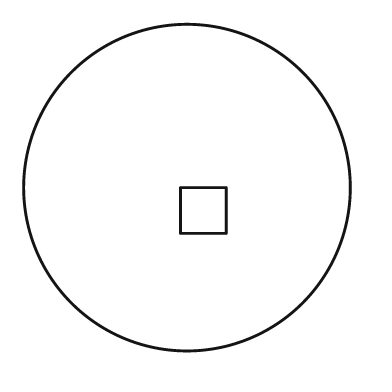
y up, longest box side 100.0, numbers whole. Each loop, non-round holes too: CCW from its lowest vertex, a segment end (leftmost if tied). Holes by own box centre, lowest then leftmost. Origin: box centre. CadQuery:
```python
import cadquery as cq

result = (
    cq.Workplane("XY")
    .moveTo(0.0, 0.0)
    .circle(50.0)
    .moveTo(-2.0, -14.0)
    .lineTo(12.0, -14.0)
    .lineTo(12.0, 0.0)
    .lineTo(-2.0, 0.0)
    .close()
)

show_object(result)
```